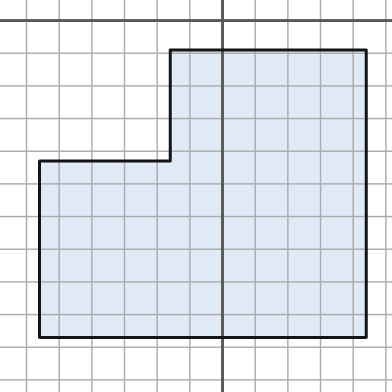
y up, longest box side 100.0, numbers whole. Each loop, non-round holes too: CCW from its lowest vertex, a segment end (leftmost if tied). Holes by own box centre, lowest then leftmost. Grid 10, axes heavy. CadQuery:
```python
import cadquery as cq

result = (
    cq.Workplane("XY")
    .moveTo(-56.0, -97.0)
    .lineTo(44.0, -97.0)
    .lineTo(44.0, -9.0)
    .lineTo(-16.0, -9.0)
    .lineTo(-16.0, -43.0)
    .lineTo(-56.0, -43.0)
    .close()
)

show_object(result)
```